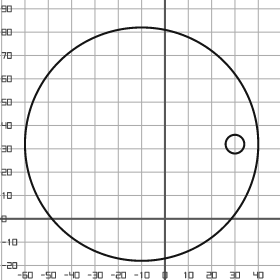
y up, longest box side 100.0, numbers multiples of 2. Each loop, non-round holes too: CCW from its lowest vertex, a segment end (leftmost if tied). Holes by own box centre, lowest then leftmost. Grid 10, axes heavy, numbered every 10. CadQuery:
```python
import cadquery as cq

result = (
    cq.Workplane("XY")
    .moveTo(-10.0, 32.0)
    .circle(50.0)
    .moveTo(30.0, 32.0)
    .circle(4.0)
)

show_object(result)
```